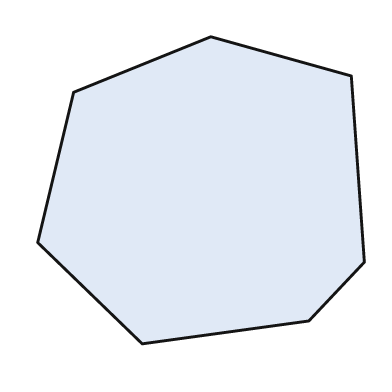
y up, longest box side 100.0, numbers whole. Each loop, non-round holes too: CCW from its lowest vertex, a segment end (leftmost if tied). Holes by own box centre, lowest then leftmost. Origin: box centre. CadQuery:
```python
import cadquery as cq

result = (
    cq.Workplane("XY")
    .moveTo(-18.0, -47.0)
    .lineTo(33.0, -40.0)
    .lineTo(50.0, -22.0)
    .lineTo(46.0, 35.0)
    .lineTo(3.0, 47.0)
    .lineTo(-39.0, 30.0)
    .lineTo(-50.0, -16.0)
    .close()
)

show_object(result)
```